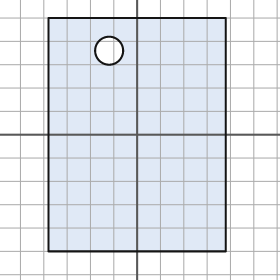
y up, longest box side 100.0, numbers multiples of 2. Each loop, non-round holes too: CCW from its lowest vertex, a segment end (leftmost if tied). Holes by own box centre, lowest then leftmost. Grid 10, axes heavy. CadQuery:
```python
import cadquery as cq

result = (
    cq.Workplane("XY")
    .moveTo(-38.0, -50.0)
    .lineTo(38.0, -50.0)
    .lineTo(38.0, 50.0)
    .lineTo(-38.0, 50.0)
    .close()
    .moveTo(-12.0, 36.0)
    .circle(6.0)
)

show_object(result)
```